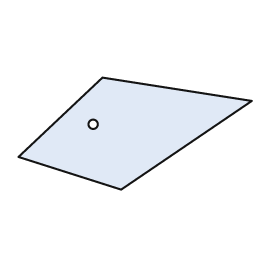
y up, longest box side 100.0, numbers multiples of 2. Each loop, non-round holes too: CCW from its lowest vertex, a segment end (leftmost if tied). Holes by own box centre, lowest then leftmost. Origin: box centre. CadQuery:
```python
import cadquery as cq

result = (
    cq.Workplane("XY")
    .moveTo(-6.0, -24.0)
    .lineTo(50.0, 14.0)
    .lineTo(-14.0, 24.0)
    .lineTo(-50.0, -10.0)
    .close()
    .moveTo(-18.0, 4.0)
    .circle(2.0)
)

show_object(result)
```